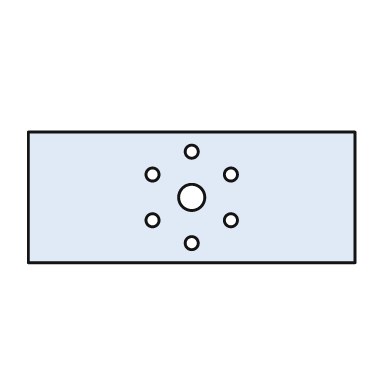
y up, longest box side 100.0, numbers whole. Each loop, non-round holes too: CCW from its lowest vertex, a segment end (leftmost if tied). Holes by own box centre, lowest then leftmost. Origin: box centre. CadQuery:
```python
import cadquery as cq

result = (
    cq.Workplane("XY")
    .moveTo(-50.0, -20.0)
    .lineTo(50.0, -20.0)
    .lineTo(50.0, 20.0)
    .lineTo(-50.0, 20.0)
    .close()
    .moveTo(0.0, -14.0)
    .circle(2.0)
    .moveTo(-12.0, -7.0)
    .circle(2.0)
    .moveTo(12.0, -7.0)
    .circle(2.0)
    .moveTo(0.0, 0.0)
    .circle(4.0)
    .moveTo(-12.0, 7.0)
    .circle(2.0)
    .moveTo(12.0, 7.0)
    .circle(2.0)
    .moveTo(0.0, 14.0)
    .circle(2.0)
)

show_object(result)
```